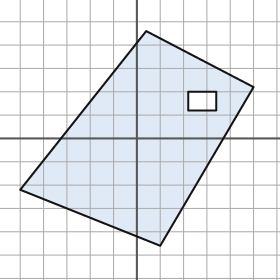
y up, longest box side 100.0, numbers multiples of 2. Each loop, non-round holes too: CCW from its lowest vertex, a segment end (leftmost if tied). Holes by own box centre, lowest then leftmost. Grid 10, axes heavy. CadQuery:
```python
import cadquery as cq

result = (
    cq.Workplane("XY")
    .moveTo(10.0, -46.0)
    .lineTo(50.0, 22.0)
    .lineTo(4.0, 46.0)
    .lineTo(-50.0, -22.0)
    .close()
    .moveTo(22.0, 12.0)
    .lineTo(34.0, 12.0)
    .lineTo(34.0, 20.0)
    .lineTo(22.0, 20.0)
    .close()
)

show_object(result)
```